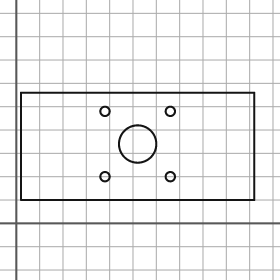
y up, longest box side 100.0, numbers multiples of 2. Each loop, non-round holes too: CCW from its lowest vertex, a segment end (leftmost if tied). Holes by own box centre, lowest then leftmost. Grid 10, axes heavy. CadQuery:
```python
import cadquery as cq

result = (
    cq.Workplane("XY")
    .moveTo(2.0, 10.0)
    .lineTo(102.0, 10.0)
    .lineTo(102.0, 56.0)
    .lineTo(2.0, 56.0)
    .close()
    .moveTo(38.0, 20.0)
    .circle(2.0)
    .moveTo(66.0, 20.0)
    .circle(2.0)
    .moveTo(52.0, 34.0)
    .circle(8.0)
    .moveTo(38.0, 48.0)
    .circle(2.0)
    .moveTo(66.0, 48.0)
    .circle(2.0)
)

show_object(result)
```